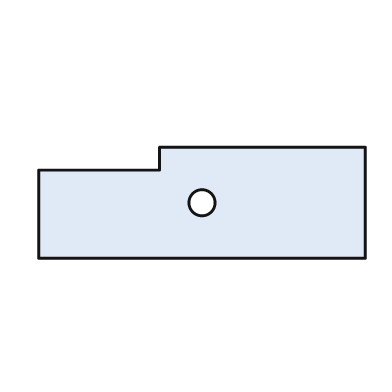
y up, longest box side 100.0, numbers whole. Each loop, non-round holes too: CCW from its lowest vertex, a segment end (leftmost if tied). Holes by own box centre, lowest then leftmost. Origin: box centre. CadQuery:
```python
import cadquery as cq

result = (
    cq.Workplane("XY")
    .moveTo(-50.0, -17.0)
    .lineTo(50.0, -17.0)
    .lineTo(50.0, 17.0)
    .lineTo(-13.0, 17.0)
    .lineTo(-13.0, 10.0)
    .lineTo(-50.0, 10.0)
    .close()
    .moveTo(0.0, 0.0)
    .circle(4.0)
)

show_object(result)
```